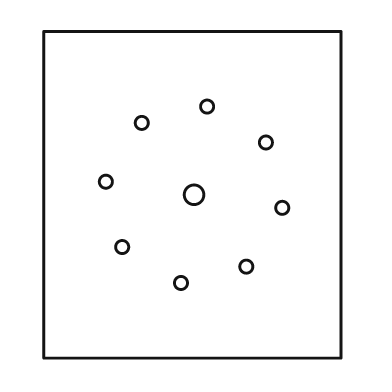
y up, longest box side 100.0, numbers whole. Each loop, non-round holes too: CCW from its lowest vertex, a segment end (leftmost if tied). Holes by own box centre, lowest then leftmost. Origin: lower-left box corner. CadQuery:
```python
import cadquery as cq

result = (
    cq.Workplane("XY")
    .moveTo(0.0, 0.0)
    .lineTo(91.0, 0.0)
    .lineTo(91.0, 100.0)
    .lineTo(0.0, 100.0)
    .close()
    .moveTo(42.0, 23.0)
    .circle(2.0)
    .moveTo(62.0, 28.0)
    .circle(2.0)
    .moveTo(24.0, 34.0)
    .circle(2.0)
    .moveTo(73.0, 46.0)
    .circle(2.0)
    .moveTo(46.0, 50.0)
    .circle(3.0)
    .moveTo(19.0, 54.0)
    .circle(2.0)
    .moveTo(68.0, 66.0)
    .circle(2.0)
    .moveTo(30.0, 72.0)
    .circle(2.0)
    .moveTo(50.0, 77.0)
    .circle(2.0)
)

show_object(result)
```